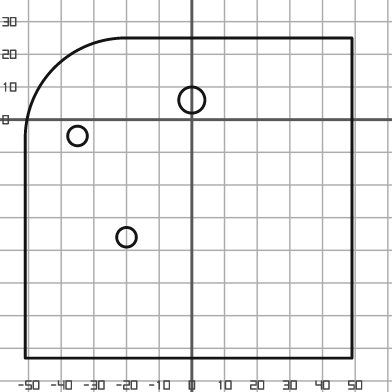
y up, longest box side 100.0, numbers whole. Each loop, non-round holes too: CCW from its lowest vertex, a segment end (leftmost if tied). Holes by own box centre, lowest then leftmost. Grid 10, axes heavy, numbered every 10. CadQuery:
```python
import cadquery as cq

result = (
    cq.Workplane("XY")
    .moveTo(-51.0, -73.0)
    .lineTo(49.0, -73.0)
    .lineTo(49.0, 25.0)
    .lineTo(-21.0, 25.0)
    .threePointArc((-42.0, 16.0), (-51.0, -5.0))
    .close()
    .moveTo(-20.0, -36.0)
    .circle(3.0)
    .moveTo(-35.0, -5.0)
    .circle(3.0)
    .moveTo(0.0, 6.0)
    .circle(4.0)
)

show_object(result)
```